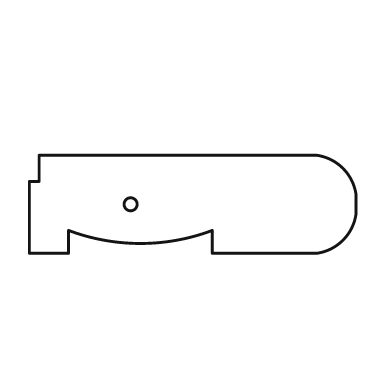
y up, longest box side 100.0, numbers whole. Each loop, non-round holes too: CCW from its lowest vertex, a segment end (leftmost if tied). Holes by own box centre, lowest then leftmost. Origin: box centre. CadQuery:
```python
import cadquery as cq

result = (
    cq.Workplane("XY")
    .moveTo(-50.0, -15.0)
    .lineTo(-38.0, -15.0)
    .lineTo(-38.0, -8.0)
    .threePointArc((-16.0, -12.0), (6.0, -8.0))
    .lineTo(6.0, -15.0)
    .lineTo(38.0, -15.0)
    .threePointArc((46.0, -11.0), (50.0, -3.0))
    .lineTo(50.0, 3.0)
    .threePointArc((46.0, 11.0), (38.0, 15.0))
    .lineTo(-47.0, 15.0)
    .lineTo(-47.0, 7.0)
    .lineTo(-50.0, 7.0)
    .close()
    .moveTo(-19.0, 0.0)
    .circle(2.0)
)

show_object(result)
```